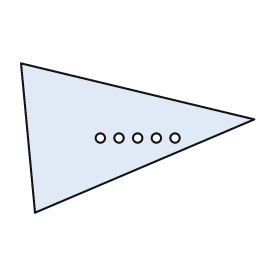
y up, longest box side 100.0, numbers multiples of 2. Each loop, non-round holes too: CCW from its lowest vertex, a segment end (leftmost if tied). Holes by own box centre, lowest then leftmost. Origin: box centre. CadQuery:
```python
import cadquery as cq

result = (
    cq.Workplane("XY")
    .moveTo(-44.0, -32.0)
    .lineTo(50.0, 8.0)
    .lineTo(-50.0, 32.0)
    .close()
    .moveTo(-16.0, 0.0)
    .circle(2.0)
    .moveTo(-8.0, 0.0)
    .circle(2.0)
    .moveTo(0.0, 0.0)
    .circle(2.0)
    .moveTo(8.0, 0.0)
    .circle(2.0)
    .moveTo(16.0, 0.0)
    .circle(2.0)
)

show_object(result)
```